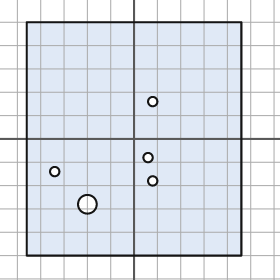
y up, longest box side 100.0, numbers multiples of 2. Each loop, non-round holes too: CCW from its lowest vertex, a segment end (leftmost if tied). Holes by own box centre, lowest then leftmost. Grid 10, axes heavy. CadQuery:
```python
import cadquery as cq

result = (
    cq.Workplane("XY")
    .moveTo(-46.0, -50.0)
    .lineTo(46.0, -50.0)
    .lineTo(46.0, 50.0)
    .lineTo(-46.0, 50.0)
    .close()
    .moveTo(-20.0, -28.0)
    .circle(4.0)
    .moveTo(8.0, -18.0)
    .circle(2.0)
    .moveTo(-34.0, -14.0)
    .circle(2.0)
    .moveTo(6.0, -8.0)
    .circle(2.0)
    .moveTo(8.0, 16.0)
    .circle(2.0)
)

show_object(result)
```